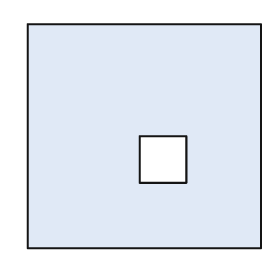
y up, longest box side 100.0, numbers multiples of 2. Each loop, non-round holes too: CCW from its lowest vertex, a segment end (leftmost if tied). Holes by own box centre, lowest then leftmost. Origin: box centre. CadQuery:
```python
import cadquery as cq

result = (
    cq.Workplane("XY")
    .moveTo(-50.0, -48.0)
    .lineTo(50.0, -48.0)
    .lineTo(50.0, 48.0)
    .lineTo(-50.0, 48.0)
    .close()
    .moveTo(-2.0, -20.0)
    .lineTo(18.0, -20.0)
    .lineTo(18.0, 0.0)
    .lineTo(-2.0, 0.0)
    .close()
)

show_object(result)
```